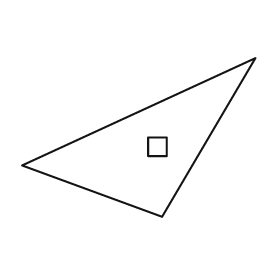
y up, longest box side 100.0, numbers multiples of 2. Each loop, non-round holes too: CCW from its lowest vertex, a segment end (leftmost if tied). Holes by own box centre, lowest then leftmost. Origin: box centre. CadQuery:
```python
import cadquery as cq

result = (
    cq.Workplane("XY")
    .moveTo(10.0, -34.0)
    .lineTo(50.0, 34.0)
    .lineTo(-50.0, -12.0)
    .close()
    .moveTo(4.0, -8.0)
    .lineTo(12.0, -8.0)
    .lineTo(12.0, 0.0)
    .lineTo(4.0, 0.0)
    .close()
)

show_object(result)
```